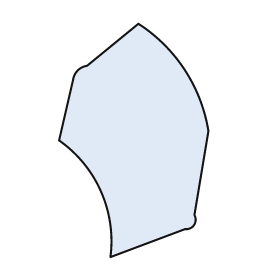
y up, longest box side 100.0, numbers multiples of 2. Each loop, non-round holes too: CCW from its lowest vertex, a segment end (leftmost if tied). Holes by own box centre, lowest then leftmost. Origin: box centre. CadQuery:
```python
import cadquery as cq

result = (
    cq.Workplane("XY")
    .moveTo(-10.0, -50.0)
    .lineTo(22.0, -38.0)
    .threePointArc((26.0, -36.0), (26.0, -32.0))
    .lineTo(32.0, 4.0)
    .threePointArc((22.0, 30.0), (2.0, 50.0))
    .lineTo(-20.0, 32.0)
    .threePointArc((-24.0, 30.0), (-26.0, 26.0))
    .lineTo(-32.0, 0.0)
    .threePointArc((-14.0, -22.0), (-10.0, -50.0))
    .close()
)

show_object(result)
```